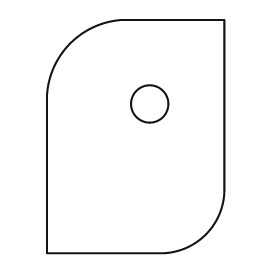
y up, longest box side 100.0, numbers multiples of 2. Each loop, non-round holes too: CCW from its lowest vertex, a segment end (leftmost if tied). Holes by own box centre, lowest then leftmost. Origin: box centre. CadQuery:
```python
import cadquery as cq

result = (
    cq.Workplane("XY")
    .moveTo(-38.0, -50.0)
    .lineTo(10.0, -50.0)
    .threePointArc((30.0, -42.0), (38.0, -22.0))
    .lineTo(38.0, 50.0)
    .lineTo(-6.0, 50.0)
    .threePointArc((-28.0, 40.0), (-38.0, 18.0))
    .close()
    .moveTo(6.0, 14.0)
    .circle(8.0)
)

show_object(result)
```